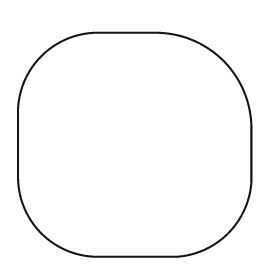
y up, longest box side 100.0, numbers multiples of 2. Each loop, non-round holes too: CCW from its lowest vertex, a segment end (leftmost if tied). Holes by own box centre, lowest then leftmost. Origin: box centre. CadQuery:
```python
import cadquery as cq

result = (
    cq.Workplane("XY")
    .moveTo(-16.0, -48.0)
    .lineTo(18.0, -48.0)
    .threePointArc((40.0, -38.0), (50.0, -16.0))
    .lineTo(50.0, 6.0)
    .threePointArc((38.0, 36.0), (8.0, 48.0))
    .lineTo(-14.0, 48.0)
    .threePointArc((-40.0, 38.0), (-50.0, 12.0))
    .lineTo(-50.0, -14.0)
    .threePointArc((-40.0, -38.0), (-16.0, -48.0))
    .close()
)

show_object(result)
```